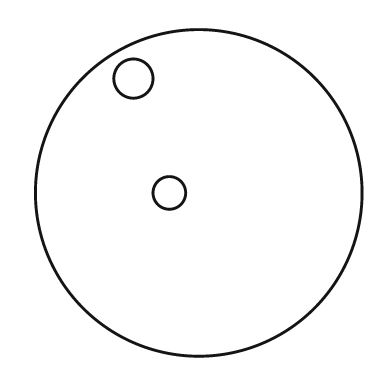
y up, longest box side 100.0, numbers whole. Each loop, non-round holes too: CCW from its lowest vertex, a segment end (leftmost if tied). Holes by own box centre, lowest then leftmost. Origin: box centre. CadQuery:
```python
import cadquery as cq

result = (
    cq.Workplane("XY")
    .moveTo(0.0, 0.0)
    .circle(50.0)
    .moveTo(-9.0, 0.0)
    .circle(5.0)
    .moveTo(-20.0, 35.0)
    .circle(6.0)
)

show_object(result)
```